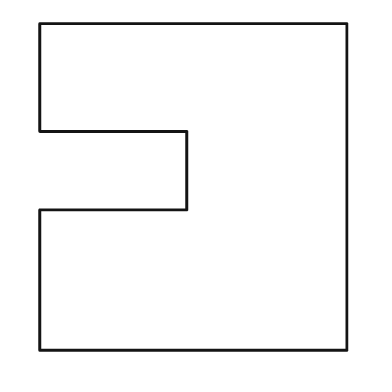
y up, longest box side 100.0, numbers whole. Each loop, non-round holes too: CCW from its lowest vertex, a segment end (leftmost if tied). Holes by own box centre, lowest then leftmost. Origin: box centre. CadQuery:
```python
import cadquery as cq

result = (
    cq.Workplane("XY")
    .moveTo(-47.0, -50.0)
    .lineTo(47.0, -50.0)
    .lineTo(47.0, 50.0)
    .lineTo(-47.0, 50.0)
    .lineTo(-47.0, 17.0)
    .lineTo(-2.0, 17.0)
    .lineTo(-2.0, -7.0)
    .lineTo(-47.0, -7.0)
    .close()
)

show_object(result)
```